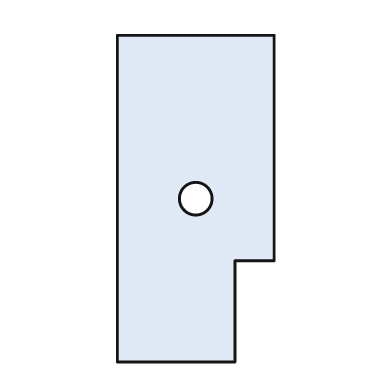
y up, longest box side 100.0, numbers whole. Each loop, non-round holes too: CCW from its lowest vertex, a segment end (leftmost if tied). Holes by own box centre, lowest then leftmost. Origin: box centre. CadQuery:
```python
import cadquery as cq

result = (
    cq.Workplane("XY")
    .moveTo(-24.0, -50.0)
    .lineTo(12.0, -50.0)
    .lineTo(12.0, -19.0)
    .lineTo(24.0, -19.0)
    .lineTo(24.0, 50.0)
    .lineTo(-24.0, 50.0)
    .close()
    .moveTo(0.0, 0.0)
    .circle(5.0)
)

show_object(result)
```